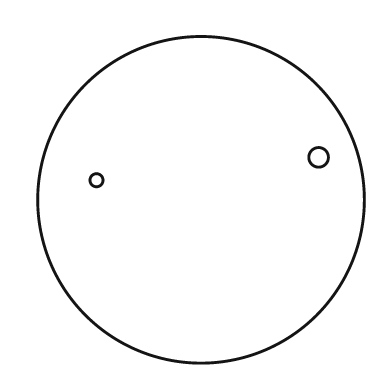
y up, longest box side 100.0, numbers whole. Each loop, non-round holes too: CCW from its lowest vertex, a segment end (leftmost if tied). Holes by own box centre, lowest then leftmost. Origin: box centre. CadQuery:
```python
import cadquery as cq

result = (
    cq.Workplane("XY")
    .moveTo(0.0, 0.0)
    .circle(50.0)
    .moveTo(-32.0, 6.0)
    .circle(2.0)
    .moveTo(36.0, 13.0)
    .circle(3.0)
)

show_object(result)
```